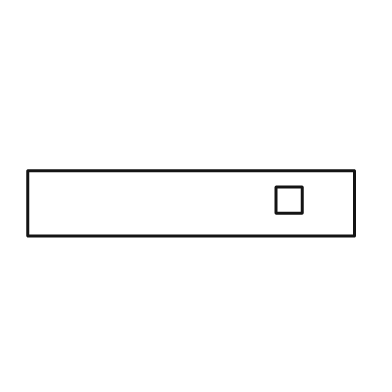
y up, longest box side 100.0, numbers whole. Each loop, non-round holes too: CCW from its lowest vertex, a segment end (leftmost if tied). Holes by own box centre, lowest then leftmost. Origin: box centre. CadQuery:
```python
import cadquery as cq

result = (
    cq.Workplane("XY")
    .moveTo(-50.0, -10.0)
    .lineTo(50.0, -10.0)
    .lineTo(50.0, 10.0)
    .lineTo(-50.0, 10.0)
    .close()
    .moveTo(26.0, -3.0)
    .lineTo(34.0, -3.0)
    .lineTo(34.0, 5.0)
    .lineTo(26.0, 5.0)
    .close()
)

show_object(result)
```